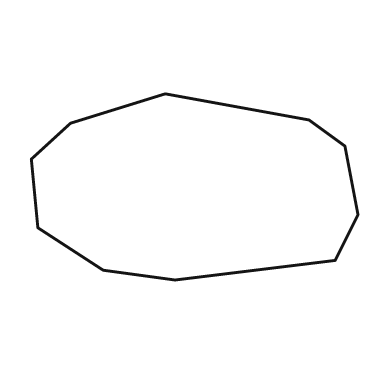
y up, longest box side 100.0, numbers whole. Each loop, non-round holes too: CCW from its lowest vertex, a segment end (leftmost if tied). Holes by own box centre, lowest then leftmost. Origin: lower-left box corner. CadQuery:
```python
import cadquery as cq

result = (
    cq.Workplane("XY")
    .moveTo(44.0, 0.0)
    .lineTo(93.0, 6.0)
    .lineTo(100.0, 20.0)
    .lineTo(96.0, 41.0)
    .lineTo(85.0, 49.0)
    .lineTo(41.0, 57.0)
    .lineTo(12.0, 48.0)
    .lineTo(0.0, 37.0)
    .lineTo(2.0, 16.0)
    .lineTo(22.0, 3.0)
    .close()
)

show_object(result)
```